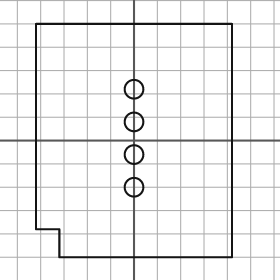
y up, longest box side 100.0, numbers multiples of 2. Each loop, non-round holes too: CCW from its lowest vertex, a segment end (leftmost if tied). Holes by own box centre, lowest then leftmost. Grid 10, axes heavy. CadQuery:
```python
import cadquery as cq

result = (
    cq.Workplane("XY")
    .moveTo(-32.0, -50.0)
    .lineTo(42.0, -50.0)
    .lineTo(42.0, 50.0)
    .lineTo(-42.0, 50.0)
    .lineTo(-42.0, -38.0)
    .lineTo(-32.0, -38.0)
    .close()
    .moveTo(0.0, -20.0)
    .circle(4.0)
    .moveTo(0.0, -6.0)
    .circle(4.0)
    .moveTo(0.0, 8.0)
    .circle(4.0)
    .moveTo(0.0, 22.0)
    .circle(4.0)
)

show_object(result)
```